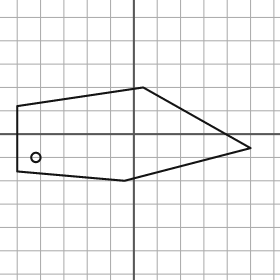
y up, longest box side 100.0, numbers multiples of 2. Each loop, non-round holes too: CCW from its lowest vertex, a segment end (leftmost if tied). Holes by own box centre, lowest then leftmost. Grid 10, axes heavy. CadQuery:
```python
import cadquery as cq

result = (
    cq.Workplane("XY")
    .moveTo(-4.0, -20.0)
    .lineTo(50.0, -6.0)
    .lineTo(4.0, 20.0)
    .lineTo(-50.0, 12.0)
    .lineTo(-50.0, -16.0)
    .close()
    .moveTo(-42.0, -10.0)
    .circle(2.0)
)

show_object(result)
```